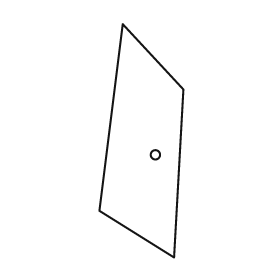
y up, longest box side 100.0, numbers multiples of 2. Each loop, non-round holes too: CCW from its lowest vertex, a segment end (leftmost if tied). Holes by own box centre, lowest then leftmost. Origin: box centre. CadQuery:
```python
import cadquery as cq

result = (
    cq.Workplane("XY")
    .moveTo(14.0, -50.0)
    .lineTo(18.0, 22.0)
    .lineTo(-8.0, 50.0)
    .lineTo(-18.0, -30.0)
    .close()
    .moveTo(6.0, -6.0)
    .circle(2.0)
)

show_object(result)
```